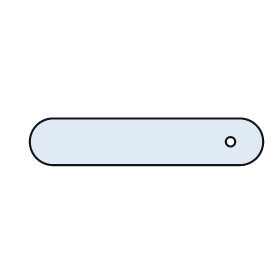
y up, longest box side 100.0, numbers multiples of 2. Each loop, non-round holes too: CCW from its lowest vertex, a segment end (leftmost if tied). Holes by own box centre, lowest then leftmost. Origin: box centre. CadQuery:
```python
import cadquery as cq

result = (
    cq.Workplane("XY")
    .moveTo(-40.0, -10.0)
    .lineTo(40.0, -10.0)
    .threePointArc((50.0, 0.0), (40.0, 10.0))
    .lineTo(-40.0, 10.0)
    .threePointArc((-50.0, 0.0), (-40.0, -10.0))
    .close()
    .moveTo(36.0, 0.0)
    .circle(2.0)
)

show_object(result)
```